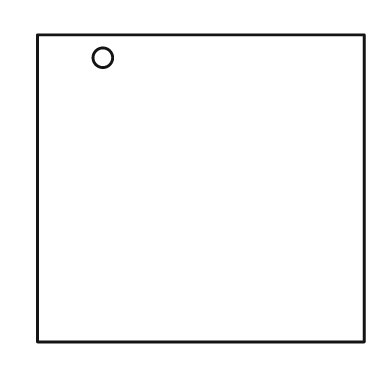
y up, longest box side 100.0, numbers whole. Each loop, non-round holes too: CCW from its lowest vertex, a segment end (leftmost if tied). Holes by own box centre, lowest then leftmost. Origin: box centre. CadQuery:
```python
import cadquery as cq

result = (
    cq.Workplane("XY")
    .moveTo(-50.0, -47.0)
    .lineTo(50.0, -47.0)
    .lineTo(50.0, 47.0)
    .lineTo(-50.0, 47.0)
    .close()
    .moveTo(-30.0, 40.0)
    .circle(3.0)
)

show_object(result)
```